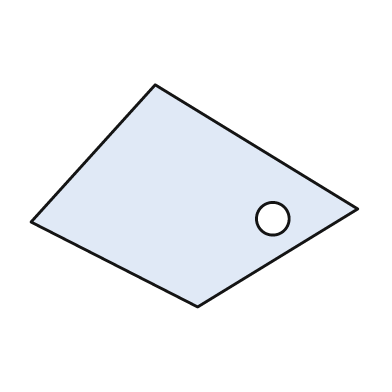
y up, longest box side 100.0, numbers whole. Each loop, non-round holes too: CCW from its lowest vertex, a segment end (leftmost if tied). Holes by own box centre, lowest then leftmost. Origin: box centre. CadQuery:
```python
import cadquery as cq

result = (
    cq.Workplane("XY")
    .moveTo(1.0, -34.0)
    .lineTo(50.0, -4.0)
    .lineTo(-12.0, 34.0)
    .lineTo(-50.0, -8.0)
    .close()
    .moveTo(24.0, -7.0)
    .circle(5.0)
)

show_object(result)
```